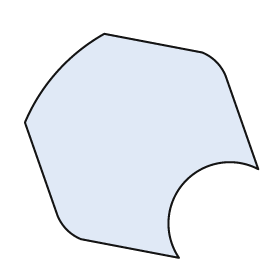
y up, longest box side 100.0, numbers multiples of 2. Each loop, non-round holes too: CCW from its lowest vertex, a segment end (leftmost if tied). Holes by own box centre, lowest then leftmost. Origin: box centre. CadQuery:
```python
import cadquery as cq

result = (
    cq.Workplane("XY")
    .moveTo(16.0, -48.0)
    .threePointArc((18.0, -16.0), (50.0, -10.0))
    .lineTo(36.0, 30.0)
    .threePointArc((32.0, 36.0), (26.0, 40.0))
    .lineTo(-16.0, 48.0)
    .threePointArc((-36.0, 32.0), (-50.0, 10.0))
    .lineTo(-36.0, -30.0)
    .threePointArc((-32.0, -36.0), (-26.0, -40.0))
    .close()
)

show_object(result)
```